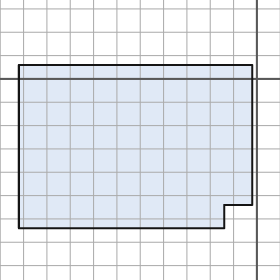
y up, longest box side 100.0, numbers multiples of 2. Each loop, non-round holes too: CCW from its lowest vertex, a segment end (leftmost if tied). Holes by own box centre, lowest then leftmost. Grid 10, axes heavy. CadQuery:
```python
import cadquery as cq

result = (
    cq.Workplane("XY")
    .moveTo(-102.0, -64.0)
    .lineTo(-14.0, -64.0)
    .lineTo(-14.0, -54.0)
    .lineTo(-2.0, -54.0)
    .lineTo(-2.0, 6.0)
    .lineTo(-102.0, 6.0)
    .close()
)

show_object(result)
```